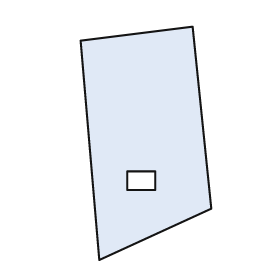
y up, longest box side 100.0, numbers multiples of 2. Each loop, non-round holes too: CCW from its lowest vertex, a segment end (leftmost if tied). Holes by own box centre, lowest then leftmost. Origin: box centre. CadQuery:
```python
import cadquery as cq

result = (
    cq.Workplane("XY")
    .moveTo(-20.0, -50.0)
    .lineTo(28.0, -28.0)
    .lineTo(20.0, 50.0)
    .lineTo(-28.0, 44.0)
    .close()
    .moveTo(-8.0, -20.0)
    .lineTo(4.0, -20.0)
    .lineTo(4.0, -12.0)
    .lineTo(-8.0, -12.0)
    .close()
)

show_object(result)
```